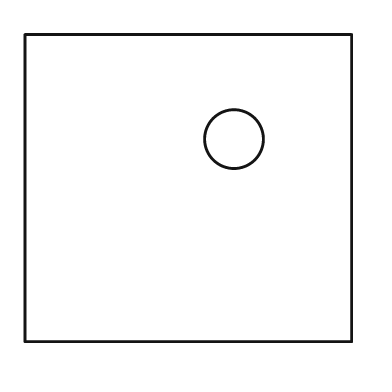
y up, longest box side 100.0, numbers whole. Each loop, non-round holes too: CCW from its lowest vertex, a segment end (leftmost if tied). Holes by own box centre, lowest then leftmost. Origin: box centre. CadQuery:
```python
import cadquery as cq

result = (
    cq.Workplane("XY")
    .moveTo(-50.0, -47.0)
    .lineTo(50.0, -47.0)
    .lineTo(50.0, 47.0)
    .lineTo(-50.0, 47.0)
    .close()
    .moveTo(14.0, 15.0)
    .circle(9.0)
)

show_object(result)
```